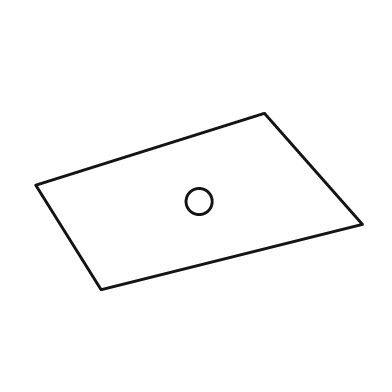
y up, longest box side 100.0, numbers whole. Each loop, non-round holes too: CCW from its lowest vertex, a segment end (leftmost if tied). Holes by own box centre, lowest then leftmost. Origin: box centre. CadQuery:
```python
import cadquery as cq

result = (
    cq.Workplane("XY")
    .moveTo(-30.0, -27.0)
    .lineTo(50.0, -7.0)
    .lineTo(20.0, 27.0)
    .lineTo(-50.0, 5.0)
    .close()
    .moveTo(0.0, 0.0)
    .circle(4.0)
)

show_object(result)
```